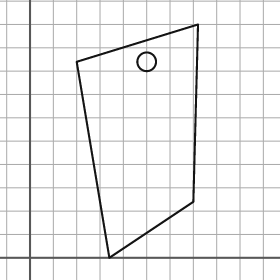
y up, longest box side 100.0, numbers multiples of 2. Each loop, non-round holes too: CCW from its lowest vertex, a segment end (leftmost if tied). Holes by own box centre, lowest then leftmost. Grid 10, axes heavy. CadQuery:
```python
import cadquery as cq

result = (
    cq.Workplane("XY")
    .moveTo(34.0, 0.0)
    .lineTo(70.0, 24.0)
    .lineTo(72.0, 100.0)
    .lineTo(20.0, 84.0)
    .close()
    .moveTo(50.0, 84.0)
    .circle(4.0)
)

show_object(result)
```